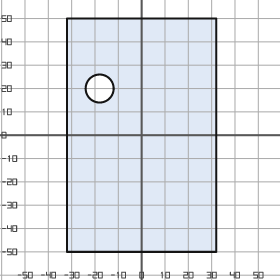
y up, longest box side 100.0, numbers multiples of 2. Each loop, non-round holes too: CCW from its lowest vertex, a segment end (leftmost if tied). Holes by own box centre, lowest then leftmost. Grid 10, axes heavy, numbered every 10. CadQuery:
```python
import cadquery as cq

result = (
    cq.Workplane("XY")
    .moveTo(-32.0, -50.0)
    .lineTo(32.0, -50.0)
    .lineTo(32.0, 50.0)
    .lineTo(-32.0, 50.0)
    .close()
    .moveTo(-18.0, 20.0)
    .circle(6.0)
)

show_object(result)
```